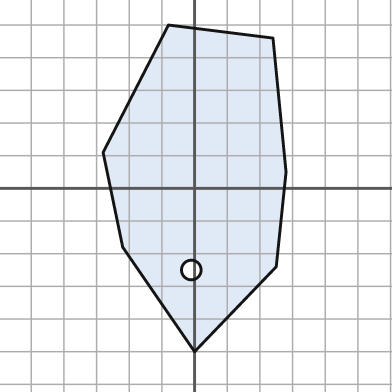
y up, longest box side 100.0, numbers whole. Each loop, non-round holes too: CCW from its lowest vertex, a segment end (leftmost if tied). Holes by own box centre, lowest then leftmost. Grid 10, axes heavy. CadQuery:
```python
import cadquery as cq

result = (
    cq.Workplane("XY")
    .moveTo(0.0, -50.0)
    .lineTo(25.0, -24.0)
    .lineTo(28.0, 5.0)
    .lineTo(24.0, 46.0)
    .lineTo(-8.0, 50.0)
    .lineTo(-28.0, 11.0)
    .lineTo(-22.0, -18.0)
    .close()
    .moveTo(-1.0, -25.0)
    .circle(3.0)
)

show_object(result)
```